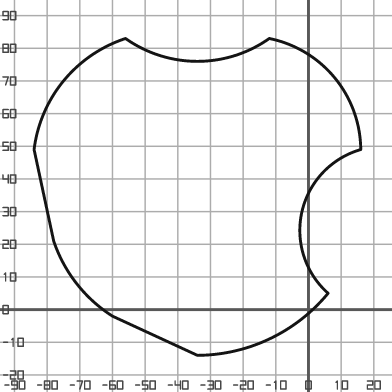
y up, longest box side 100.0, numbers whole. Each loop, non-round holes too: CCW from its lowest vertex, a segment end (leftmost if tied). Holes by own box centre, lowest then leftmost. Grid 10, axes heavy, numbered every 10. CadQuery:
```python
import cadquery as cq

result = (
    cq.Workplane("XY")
    .moveTo(-34.0, -14.0)
    .threePointArc((-12.0, -9.0), (6.0, 5.0))
    .threePointArc((-2.0, 30.0), (16.0, 49.0))
    .threePointArc((8.0, 71.0), (-12.0, 83.0))
    .threePointArc((-34.0, 76.0), (-56.0, 83.0))
    .threePointArc((-75.0, 70.0), (-84.0, 49.0))
    .lineTo(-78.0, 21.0)
    .threePointArc((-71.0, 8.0), (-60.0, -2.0))
    .close()
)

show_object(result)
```